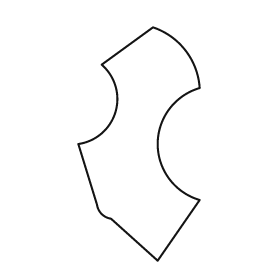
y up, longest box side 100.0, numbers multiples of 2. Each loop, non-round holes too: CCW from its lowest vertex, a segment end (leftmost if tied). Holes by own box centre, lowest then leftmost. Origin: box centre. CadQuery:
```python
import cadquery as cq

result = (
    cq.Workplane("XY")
    .moveTo(8.0, -50.0)
    .lineTo(26.0, -24.0)
    .threePointArc((8.0, 0.0), (26.0, 24.0))
    .threePointArc((20.0, 40.0), (6.0, 50.0))
    .lineTo(-16.0, 34.0)
    .threePointArc((-10.0, 14.0), (-26.0, 0.0))
    .lineTo(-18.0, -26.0)
    .threePointArc((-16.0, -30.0), (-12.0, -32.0))
    .close()
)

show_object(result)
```